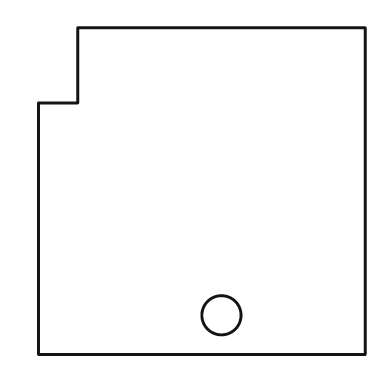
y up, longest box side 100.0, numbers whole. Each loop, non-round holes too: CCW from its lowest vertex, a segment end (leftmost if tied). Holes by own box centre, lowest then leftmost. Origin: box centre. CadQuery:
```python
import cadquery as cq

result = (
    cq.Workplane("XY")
    .moveTo(-50.0, -50.0)
    .lineTo(50.0, -50.0)
    .lineTo(50.0, 50.0)
    .lineTo(-38.0, 50.0)
    .lineTo(-38.0, 27.0)
    .lineTo(-50.0, 27.0)
    .close()
    .moveTo(6.0, -38.0)
    .circle(6.0)
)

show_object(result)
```